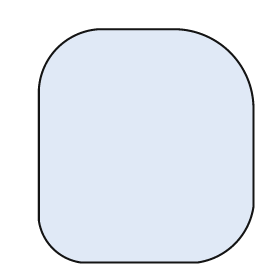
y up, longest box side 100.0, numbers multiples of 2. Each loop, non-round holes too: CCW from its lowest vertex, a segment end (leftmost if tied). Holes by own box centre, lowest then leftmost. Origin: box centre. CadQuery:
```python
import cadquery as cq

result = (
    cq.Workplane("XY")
    .moveTo(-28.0, -50.0)
    .lineTo(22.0, -50.0)
    .threePointArc((38.0, -42.0), (46.0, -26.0))
    .lineTo(46.0, 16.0)
    .threePointArc((36.0, 40.0), (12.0, 50.0))
    .lineTo(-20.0, 50.0)
    .threePointArc((-38.0, 42.0), (-46.0, 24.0))
    .lineTo(-46.0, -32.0)
    .threePointArc((-40.0, -44.0), (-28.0, -50.0))
    .close()
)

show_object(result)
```